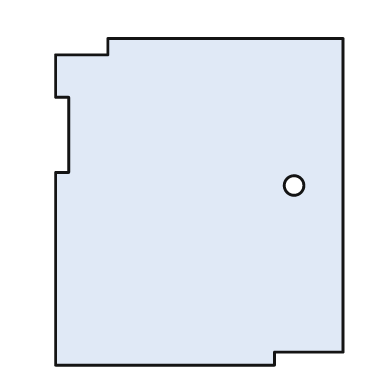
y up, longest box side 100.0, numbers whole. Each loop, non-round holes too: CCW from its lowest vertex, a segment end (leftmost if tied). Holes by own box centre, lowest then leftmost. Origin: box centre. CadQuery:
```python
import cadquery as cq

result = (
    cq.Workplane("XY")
    .moveTo(-44.0, -50.0)
    .lineTo(23.0, -50.0)
    .lineTo(23.0, -46.0)
    .lineTo(44.0, -46.0)
    .lineTo(44.0, 50.0)
    .lineTo(-28.0, 50.0)
    .lineTo(-28.0, 45.0)
    .lineTo(-44.0, 45.0)
    .lineTo(-44.0, 32.0)
    .lineTo(-40.0, 32.0)
    .lineTo(-40.0, 9.0)
    .lineTo(-44.0, 9.0)
    .close()
    .moveTo(29.0, 5.0)
    .circle(3.0)
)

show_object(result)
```